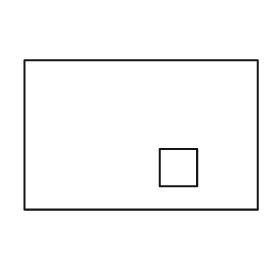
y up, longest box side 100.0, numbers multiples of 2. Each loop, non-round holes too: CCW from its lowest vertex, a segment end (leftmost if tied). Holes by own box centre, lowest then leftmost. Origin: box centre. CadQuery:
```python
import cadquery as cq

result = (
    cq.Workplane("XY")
    .moveTo(-50.0, -32.0)
    .lineTo(50.0, -32.0)
    .lineTo(50.0, 32.0)
    .lineTo(-50.0, 32.0)
    .close()
    .moveTo(8.0, -22.0)
    .lineTo(24.0, -22.0)
    .lineTo(24.0, -6.0)
    .lineTo(8.0, -6.0)
    .close()
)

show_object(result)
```